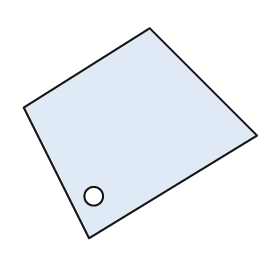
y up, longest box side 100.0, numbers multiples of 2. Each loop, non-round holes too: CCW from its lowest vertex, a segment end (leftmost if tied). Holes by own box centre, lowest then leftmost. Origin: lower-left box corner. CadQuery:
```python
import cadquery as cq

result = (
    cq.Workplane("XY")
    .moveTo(28.0, 0.0)
    .lineTo(100.0, 44.0)
    .lineTo(54.0, 90.0)
    .lineTo(0.0, 56.0)
    .close()
    .moveTo(30.0, 18.0)
    .circle(4.0)
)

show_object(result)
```